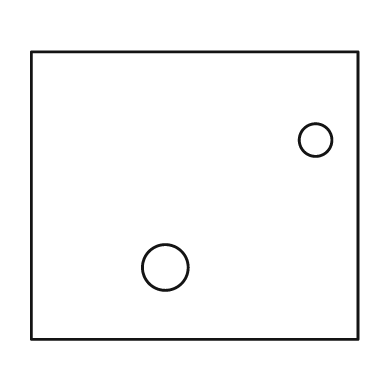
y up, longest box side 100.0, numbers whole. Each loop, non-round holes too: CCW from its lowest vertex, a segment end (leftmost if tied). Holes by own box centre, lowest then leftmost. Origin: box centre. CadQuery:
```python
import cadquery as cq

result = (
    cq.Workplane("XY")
    .moveTo(-50.0, -44.0)
    .lineTo(50.0, -44.0)
    .lineTo(50.0, 44.0)
    .lineTo(-50.0, 44.0)
    .close()
    .moveTo(-9.0, -22.0)
    .circle(7.0)
    .moveTo(37.0, 17.0)
    .circle(5.0)
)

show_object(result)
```